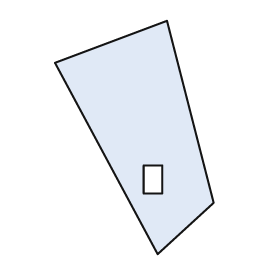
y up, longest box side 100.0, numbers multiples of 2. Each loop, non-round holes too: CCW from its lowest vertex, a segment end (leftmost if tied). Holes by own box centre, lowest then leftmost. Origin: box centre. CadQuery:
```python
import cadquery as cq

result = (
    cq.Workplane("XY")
    .moveTo(10.0, -50.0)
    .lineTo(34.0, -28.0)
    .lineTo(14.0, 50.0)
    .lineTo(-34.0, 32.0)
    .close()
    .moveTo(4.0, -24.0)
    .lineTo(12.0, -24.0)
    .lineTo(12.0, -12.0)
    .lineTo(4.0, -12.0)
    .close()
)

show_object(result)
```